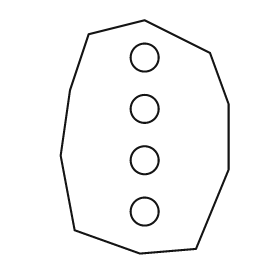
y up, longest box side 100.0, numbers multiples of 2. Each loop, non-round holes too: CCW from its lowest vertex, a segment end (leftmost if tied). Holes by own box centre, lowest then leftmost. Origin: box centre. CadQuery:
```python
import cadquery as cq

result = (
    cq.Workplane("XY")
    .moveTo(-2.0, -50.0)
    .lineTo(22.0, -48.0)
    .lineTo(36.0, -14.0)
    .lineTo(36.0, 14.0)
    .lineTo(28.0, 36.0)
    .lineTo(0.0, 50.0)
    .lineTo(-24.0, 44.0)
    .lineTo(-32.0, 20.0)
    .lineTo(-36.0, -8.0)
    .lineTo(-30.0, -40.0)
    .close()
    .moveTo(0.0, -32.0)
    .circle(6.0)
    .moveTo(0.0, -10.0)
    .circle(6.0)
    .moveTo(0.0, 12.0)
    .circle(6.0)
    .moveTo(0.0, 34.0)
    .circle(6.0)
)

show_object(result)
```